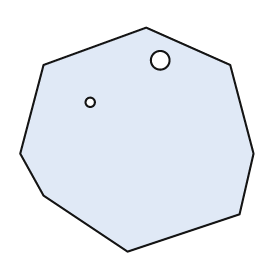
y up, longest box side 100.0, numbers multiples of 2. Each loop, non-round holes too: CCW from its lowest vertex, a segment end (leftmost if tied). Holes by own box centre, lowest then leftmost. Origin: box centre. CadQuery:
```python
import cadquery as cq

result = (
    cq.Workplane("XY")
    .moveTo(-4.0, -48.0)
    .lineTo(44.0, -32.0)
    .lineTo(50.0, -6.0)
    .lineTo(40.0, 32.0)
    .lineTo(4.0, 48.0)
    .lineTo(-40.0, 32.0)
    .lineTo(-50.0, -6.0)
    .lineTo(-40.0, -24.0)
    .close()
    .moveTo(-20.0, 16.0)
    .circle(2.0)
    .moveTo(10.0, 34.0)
    .circle(4.0)
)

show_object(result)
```